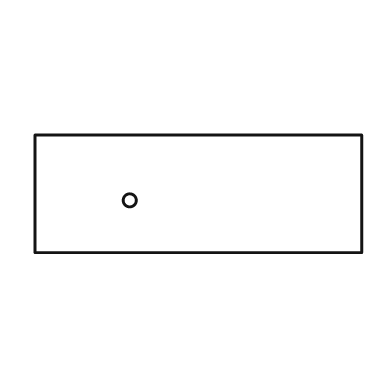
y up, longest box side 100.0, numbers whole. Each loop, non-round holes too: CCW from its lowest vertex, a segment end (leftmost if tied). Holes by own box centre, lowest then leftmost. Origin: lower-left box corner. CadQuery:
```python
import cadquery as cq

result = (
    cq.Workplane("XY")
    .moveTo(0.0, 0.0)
    .lineTo(100.0, 0.0)
    .lineTo(100.0, 36.0)
    .lineTo(0.0, 36.0)
    .close()
    .moveTo(29.0, 16.0)
    .circle(2.0)
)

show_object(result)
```